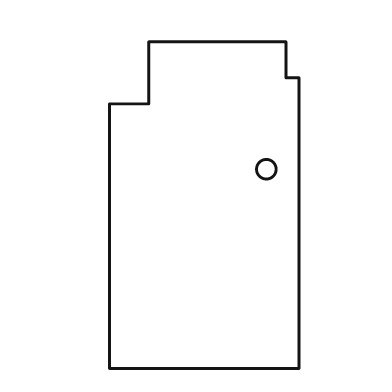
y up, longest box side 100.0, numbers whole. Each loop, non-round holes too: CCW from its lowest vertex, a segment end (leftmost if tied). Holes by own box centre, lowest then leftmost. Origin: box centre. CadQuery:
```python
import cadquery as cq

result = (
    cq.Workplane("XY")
    .moveTo(-29.0, -50.0)
    .lineTo(29.0, -50.0)
    .lineTo(29.0, 39.0)
    .lineTo(25.0, 39.0)
    .lineTo(25.0, 50.0)
    .lineTo(-17.0, 50.0)
    .lineTo(-17.0, 31.0)
    .lineTo(-29.0, 31.0)
    .close()
    .moveTo(19.0, 11.0)
    .circle(3.0)
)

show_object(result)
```